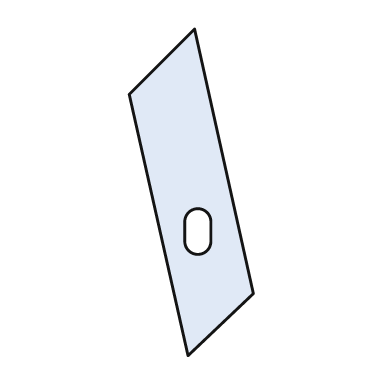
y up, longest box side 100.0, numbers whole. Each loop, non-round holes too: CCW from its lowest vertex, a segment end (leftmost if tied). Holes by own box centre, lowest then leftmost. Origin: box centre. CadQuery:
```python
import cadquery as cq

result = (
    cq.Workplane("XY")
    .moveTo(-1.0, -50.0)
    .lineTo(19.0, -31.0)
    .lineTo(1.0, 50.0)
    .lineTo(-19.0, 30.0)
    .close()
    .moveTo(-2.0, -15.0)
    .threePointArc((2.0, -19.0), (6.0, -15.0))
    .lineTo(6.0, -9.0)
    .threePointArc((2.0, -5.0), (-2.0, -9.0))
    .close()
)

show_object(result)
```